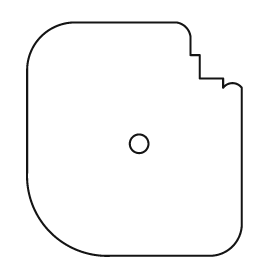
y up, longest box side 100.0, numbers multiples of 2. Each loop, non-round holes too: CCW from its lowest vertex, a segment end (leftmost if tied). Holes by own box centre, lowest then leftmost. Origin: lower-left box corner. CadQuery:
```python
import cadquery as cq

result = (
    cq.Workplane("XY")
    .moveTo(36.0, 0.0)
    .lineTo(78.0, 0.0)
    .threePointArc((88.0, 4.0), (92.0, 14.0))
    .lineTo(92.0, 72.0)
    .threePointArc((88.0, 74.0), (84.0, 72.0))
    .lineTo(84.0, 76.0)
    .lineTo(74.0, 76.0)
    .lineTo(74.0, 86.0)
    .lineTo(70.0, 86.0)
    .lineTo(70.0, 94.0)
    .threePointArc((68.0, 98.0), (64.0, 100.0))
    .lineTo(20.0, 100.0)
    .threePointArc((6.0, 94.0), (0.0, 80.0))
    .lineTo(0.0, 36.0)
    .threePointArc((10.0, 10.0), (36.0, 0.0))
    .close()
    .moveTo(48.0, 48.0)
    .circle(4.0)
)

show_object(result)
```